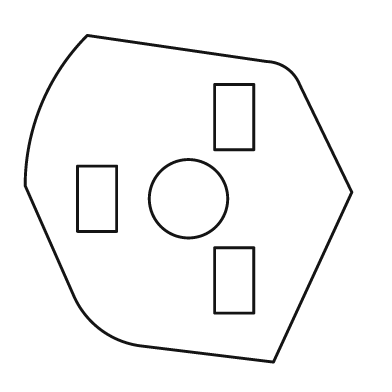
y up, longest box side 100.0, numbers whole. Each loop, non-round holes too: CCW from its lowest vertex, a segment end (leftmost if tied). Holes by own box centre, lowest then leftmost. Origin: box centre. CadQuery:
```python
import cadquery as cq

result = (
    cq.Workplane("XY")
    .moveTo(26.0, -50.0)
    .lineTo(50.0, 2.0)
    .lineTo(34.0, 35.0)
    .threePointArc((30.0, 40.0), (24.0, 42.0))
    .lineTo(-31.0, 50.0)
    .threePointArc((-45.0, 29.0), (-50.0, 4.0))
    .lineTo(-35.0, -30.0)
    .threePointArc((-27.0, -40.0), (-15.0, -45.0))
    .close()
    .moveTo(8.0, -35.0)
    .lineTo(20.0, -35.0)
    .lineTo(20.0, -15.0)
    .lineTo(8.0, -15.0)
    .close()
    .moveTo(-34.0, -10.0)
    .lineTo(-22.0, -10.0)
    .lineTo(-22.0, 10.0)
    .lineTo(-34.0, 10.0)
    .close()
    .moveTo(0.0, 0.0)
    .circle(12.0)
    .moveTo(8.0, 15.0)
    .lineTo(20.0, 15.0)
    .lineTo(20.0, 35.0)
    .lineTo(8.0, 35.0)
    .close()
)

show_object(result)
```